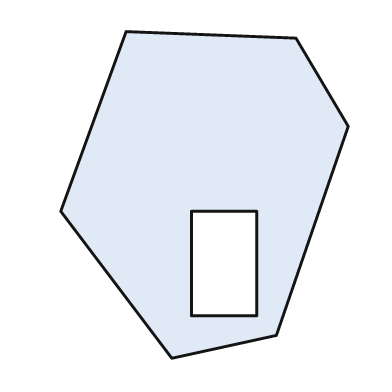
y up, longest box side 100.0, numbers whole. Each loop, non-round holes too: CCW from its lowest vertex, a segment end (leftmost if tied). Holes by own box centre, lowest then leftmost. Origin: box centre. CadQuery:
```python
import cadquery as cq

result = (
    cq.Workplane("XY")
    .moveTo(-10.0, -50.0)
    .lineTo(22.0, -43.0)
    .lineTo(44.0, 21.0)
    .lineTo(28.0, 48.0)
    .lineTo(-24.0, 50.0)
    .lineTo(-44.0, -5.0)
    .close()
    .moveTo(-4.0, -37.0)
    .lineTo(16.0, -37.0)
    .lineTo(16.0, -5.0)
    .lineTo(-4.0, -5.0)
    .close()
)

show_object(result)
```